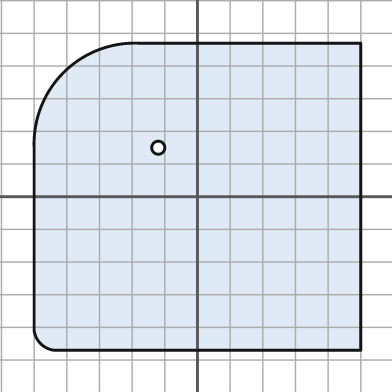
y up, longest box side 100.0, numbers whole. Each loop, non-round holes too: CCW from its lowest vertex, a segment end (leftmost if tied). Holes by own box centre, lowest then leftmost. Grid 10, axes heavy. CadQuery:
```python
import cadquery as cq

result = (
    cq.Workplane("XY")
    .moveTo(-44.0, -47.0)
    .lineTo(50.0, -47.0)
    .lineTo(50.0, 47.0)
    .lineTo(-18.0, 47.0)
    .threePointArc((-41.0, 38.0), (-50.0, 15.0))
    .lineTo(-50.0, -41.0)
    .threePointArc((-48.0, -45.0), (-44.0, -47.0))
    .close()
    .moveTo(-12.0, 15.0)
    .circle(2.0)
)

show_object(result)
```